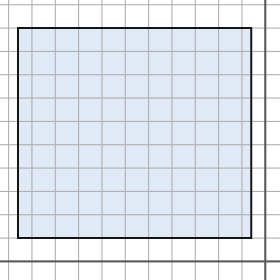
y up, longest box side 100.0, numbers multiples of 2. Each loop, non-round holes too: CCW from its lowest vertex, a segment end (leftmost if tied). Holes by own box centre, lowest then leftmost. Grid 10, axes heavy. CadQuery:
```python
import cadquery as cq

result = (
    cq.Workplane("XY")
    .moveTo(-106.0, 10.0)
    .lineTo(-6.0, 10.0)
    .lineTo(-6.0, 100.0)
    .lineTo(-106.0, 100.0)
    .close()
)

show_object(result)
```